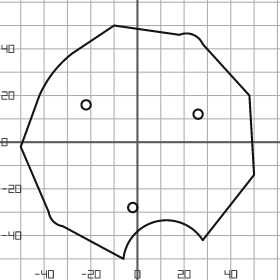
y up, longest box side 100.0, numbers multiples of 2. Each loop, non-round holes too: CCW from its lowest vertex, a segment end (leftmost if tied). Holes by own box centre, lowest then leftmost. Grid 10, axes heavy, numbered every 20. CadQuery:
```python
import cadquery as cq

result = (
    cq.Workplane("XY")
    .moveTo(-6.0, -50.0)
    .threePointArc((8.0, -34.0), (28.0, -42.0))
    .lineTo(50.0, -14.0)
    .lineTo(48.0, 20.0)
    .lineTo(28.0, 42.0)
    .threePointArc((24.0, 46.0), (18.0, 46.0))
    .lineTo(-10.0, 50.0)
    .lineTo(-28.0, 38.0)
    .threePointArc((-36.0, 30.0), (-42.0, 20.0))
    .lineTo(-50.0, -2.0)
    .lineTo(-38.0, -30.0)
    .threePointArc((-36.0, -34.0), (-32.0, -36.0))
    .close()
    .moveTo(-2.0, -28.0)
    .circle(2.0)
    .moveTo(26.0, 12.0)
    .circle(2.0)
    .moveTo(-22.0, 16.0)
    .circle(2.0)
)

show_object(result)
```